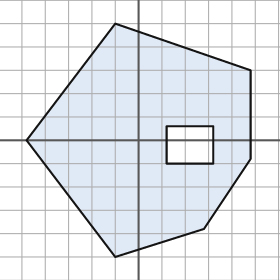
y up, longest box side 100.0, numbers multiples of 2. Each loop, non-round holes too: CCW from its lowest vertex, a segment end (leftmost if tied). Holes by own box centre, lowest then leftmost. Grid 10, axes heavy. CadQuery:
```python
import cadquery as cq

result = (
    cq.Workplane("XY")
    .moveTo(-10.0, -50.0)
    .lineTo(28.0, -38.0)
    .lineTo(48.0, -8.0)
    .lineTo(48.0, 30.0)
    .lineTo(-10.0, 50.0)
    .lineTo(-48.0, 0.0)
    .close()
    .moveTo(12.0, -10.0)
    .lineTo(32.0, -10.0)
    .lineTo(32.0, 6.0)
    .lineTo(12.0, 6.0)
    .close()
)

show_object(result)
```